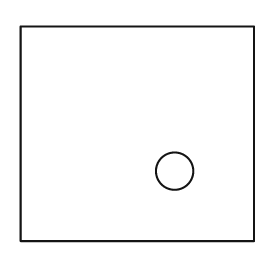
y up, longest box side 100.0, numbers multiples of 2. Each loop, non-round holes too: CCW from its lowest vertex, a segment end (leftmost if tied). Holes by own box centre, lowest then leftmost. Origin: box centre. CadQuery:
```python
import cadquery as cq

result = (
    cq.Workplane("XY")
    .moveTo(-50.0, -46.0)
    .lineTo(50.0, -46.0)
    .lineTo(50.0, 46.0)
    .lineTo(-50.0, 46.0)
    .close()
    .moveTo(16.0, -16.0)
    .circle(8.0)
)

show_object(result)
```